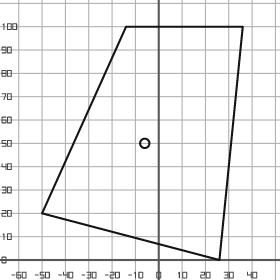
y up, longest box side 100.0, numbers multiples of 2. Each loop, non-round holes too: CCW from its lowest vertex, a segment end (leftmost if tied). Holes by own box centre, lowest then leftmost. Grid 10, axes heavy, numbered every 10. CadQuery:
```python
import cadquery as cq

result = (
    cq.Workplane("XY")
    .moveTo(26.0, 0.0)
    .lineTo(36.0, 100.0)
    .lineTo(-14.0, 100.0)
    .lineTo(-50.0, 20.0)
    .close()
    .moveTo(-6.0, 50.0)
    .circle(2.0)
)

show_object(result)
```